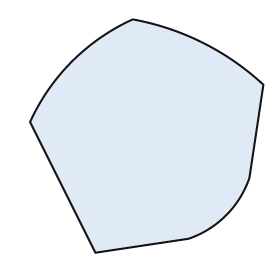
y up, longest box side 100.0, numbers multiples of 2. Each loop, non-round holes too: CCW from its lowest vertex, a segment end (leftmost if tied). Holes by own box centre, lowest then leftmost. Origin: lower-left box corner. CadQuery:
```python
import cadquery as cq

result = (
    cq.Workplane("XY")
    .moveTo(28.0, 0.0)
    .lineTo(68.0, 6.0)
    .threePointArc((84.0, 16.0), (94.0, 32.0))
    .lineTo(100.0, 72.0)
    .threePointArc((74.0, 90.0), (44.0, 100.0))
    .threePointArc((18.0, 82.0), (0.0, 56.0))
    .close()
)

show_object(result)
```